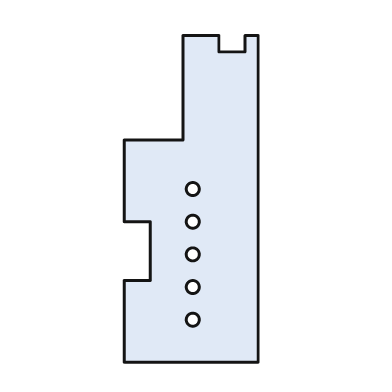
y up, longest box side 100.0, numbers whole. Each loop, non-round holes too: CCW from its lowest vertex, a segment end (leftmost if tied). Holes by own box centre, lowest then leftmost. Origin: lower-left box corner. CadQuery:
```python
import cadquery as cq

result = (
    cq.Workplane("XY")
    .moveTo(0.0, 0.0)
    .lineTo(41.0, 0.0)
    .lineTo(41.0, 100.0)
    .lineTo(37.0, 100.0)
    .lineTo(37.0, 95.0)
    .lineTo(29.0, 95.0)
    .lineTo(29.0, 100.0)
    .lineTo(18.0, 100.0)
    .lineTo(18.0, 68.0)
    .lineTo(0.0, 68.0)
    .lineTo(0.0, 43.0)
    .lineTo(8.0, 43.0)
    .lineTo(8.0, 25.0)
    .lineTo(0.0, 25.0)
    .close()
    .moveTo(21.0, 13.0)
    .circle(2.0)
    .moveTo(21.0, 23.0)
    .circle(2.0)
    .moveTo(21.0, 33.0)
    .circle(2.0)
    .moveTo(21.0, 43.0)
    .circle(2.0)
    .moveTo(21.0, 53.0)
    .circle(2.0)
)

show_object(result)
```